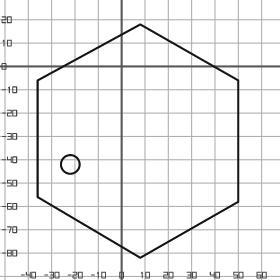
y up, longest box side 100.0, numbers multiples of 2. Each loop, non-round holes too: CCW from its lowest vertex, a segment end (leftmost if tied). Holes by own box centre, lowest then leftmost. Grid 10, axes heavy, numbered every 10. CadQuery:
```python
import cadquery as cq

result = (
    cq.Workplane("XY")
    .moveTo(8.0, -82.0)
    .lineTo(50.0, -58.0)
    .lineTo(50.0, -6.0)
    .lineTo(8.0, 18.0)
    .lineTo(-36.0, -6.0)
    .lineTo(-36.0, -56.0)
    .close()
    .moveTo(-22.0, -42.0)
    .circle(4.0)
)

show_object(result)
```